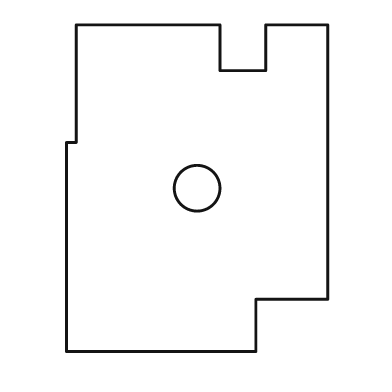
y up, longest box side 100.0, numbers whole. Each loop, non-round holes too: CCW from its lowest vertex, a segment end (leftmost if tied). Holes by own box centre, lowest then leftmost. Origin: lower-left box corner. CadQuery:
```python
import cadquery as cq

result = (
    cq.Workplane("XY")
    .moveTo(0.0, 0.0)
    .lineTo(58.0, 0.0)
    .lineTo(58.0, 16.0)
    .lineTo(80.0, 16.0)
    .lineTo(80.0, 100.0)
    .lineTo(61.0, 100.0)
    .lineTo(61.0, 86.0)
    .lineTo(47.0, 86.0)
    .lineTo(47.0, 100.0)
    .lineTo(3.0, 100.0)
    .lineTo(3.0, 64.0)
    .lineTo(0.0, 64.0)
    .close()
    .moveTo(40.0, 50.0)
    .circle(7.0)
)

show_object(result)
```